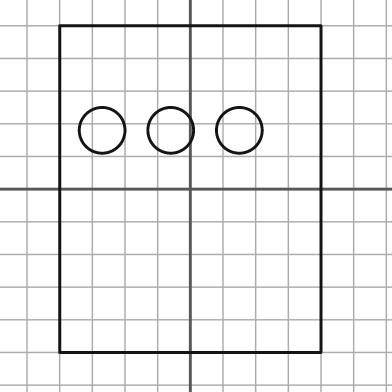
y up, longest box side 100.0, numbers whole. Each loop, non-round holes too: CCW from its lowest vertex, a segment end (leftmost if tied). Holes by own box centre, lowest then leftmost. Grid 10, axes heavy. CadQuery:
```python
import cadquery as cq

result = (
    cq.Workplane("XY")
    .moveTo(-40.0, -50.0)
    .lineTo(40.0, -50.0)
    .lineTo(40.0, 50.0)
    .lineTo(-40.0, 50.0)
    .close()
    .moveTo(-27.0, 18.0)
    .circle(7.0)
    .moveTo(-6.0, 18.0)
    .circle(7.0)
    .moveTo(15.0, 18.0)
    .circle(7.0)
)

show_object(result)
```